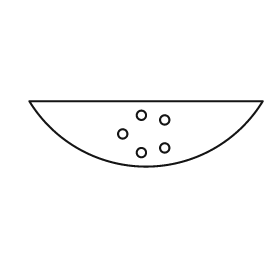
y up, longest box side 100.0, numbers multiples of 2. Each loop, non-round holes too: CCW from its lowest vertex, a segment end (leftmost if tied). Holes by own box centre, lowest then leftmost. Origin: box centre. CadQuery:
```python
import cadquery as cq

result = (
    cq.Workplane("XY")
    .moveTo(-50.0, 14.0)
    .threePointArc((0.0, -14.0), (50.0, 14.0))
    .close()
    .moveTo(-2.0, -8.0)
    .circle(2.0)
    .moveTo(8.0, -6.0)
    .circle(2.0)
    .moveTo(-10.0, 0.0)
    .circle(2.0)
    .moveTo(8.0, 6.0)
    .circle(2.0)
    .moveTo(-2.0, 8.0)
    .circle(2.0)
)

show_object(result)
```